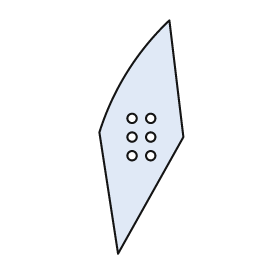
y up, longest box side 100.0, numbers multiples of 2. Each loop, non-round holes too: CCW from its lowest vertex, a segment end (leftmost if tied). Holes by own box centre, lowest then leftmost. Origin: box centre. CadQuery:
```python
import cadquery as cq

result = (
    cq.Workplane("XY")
    .moveTo(-10.0, -50.0)
    .lineTo(18.0, 0.0)
    .lineTo(12.0, 50.0)
    .threePointArc((-6.0, 28.0), (-18.0, 2.0))
    .close()
    .moveTo(-4.0, -8.0)
    .circle(2.0)
    .moveTo(4.0, -8.0)
    .circle(2.0)
    .moveTo(-4.0, 0.0)
    .circle(2.0)
    .moveTo(4.0, 0.0)
    .circle(2.0)
    .moveTo(-4.0, 8.0)
    .circle(2.0)
    .moveTo(4.0, 8.0)
    .circle(2.0)
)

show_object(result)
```